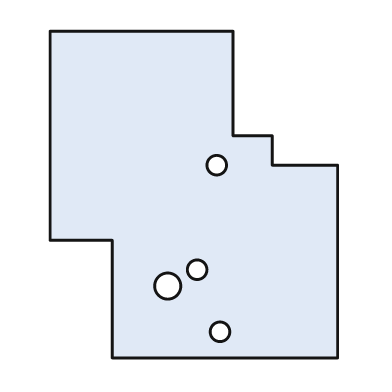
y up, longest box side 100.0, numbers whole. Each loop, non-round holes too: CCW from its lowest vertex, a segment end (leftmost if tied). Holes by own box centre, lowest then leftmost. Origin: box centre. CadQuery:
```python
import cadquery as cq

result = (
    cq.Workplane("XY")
    .moveTo(-25.0, -50.0)
    .lineTo(44.0, -50.0)
    .lineTo(44.0, 9.0)
    .lineTo(24.0, 9.0)
    .lineTo(24.0, 18.0)
    .lineTo(12.0, 18.0)
    .lineTo(12.0, 50.0)
    .lineTo(-44.0, 50.0)
    .lineTo(-44.0, -14.0)
    .lineTo(-25.0, -14.0)
    .close()
    .moveTo(8.0, -42.0)
    .circle(3.0)
    .moveTo(-8.0, -28.0)
    .circle(4.0)
    .moveTo(1.0, -23.0)
    .circle(3.0)
    .moveTo(7.0, 9.0)
    .circle(3.0)
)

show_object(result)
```